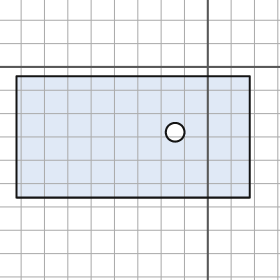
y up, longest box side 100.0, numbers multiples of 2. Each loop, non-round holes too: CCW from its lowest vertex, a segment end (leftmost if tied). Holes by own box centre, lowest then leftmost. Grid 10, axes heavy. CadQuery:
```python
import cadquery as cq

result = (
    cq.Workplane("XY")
    .moveTo(-82.0, -56.0)
    .lineTo(18.0, -56.0)
    .lineTo(18.0, -4.0)
    .lineTo(-82.0, -4.0)
    .close()
    .moveTo(-14.0, -28.0)
    .circle(4.0)
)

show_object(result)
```